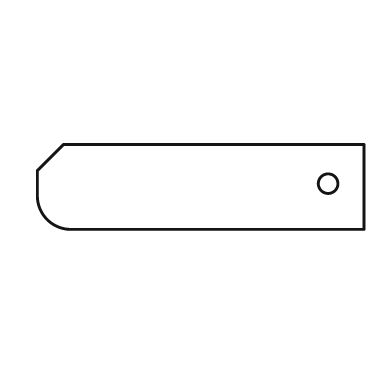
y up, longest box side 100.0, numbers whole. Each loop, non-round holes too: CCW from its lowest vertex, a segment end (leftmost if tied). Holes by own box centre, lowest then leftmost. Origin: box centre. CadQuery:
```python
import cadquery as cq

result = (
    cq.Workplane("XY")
    .moveTo(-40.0, -13.0)
    .lineTo(50.0, -13.0)
    .lineTo(50.0, 13.0)
    .lineTo(-42.0, 13.0)
    .lineTo(-50.0, 5.0)
    .lineTo(-50.0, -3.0)
    .threePointArc((-47.0, -10.0), (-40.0, -13.0))
    .close()
    .moveTo(39.0, 1.0)
    .circle(3.0)
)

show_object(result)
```